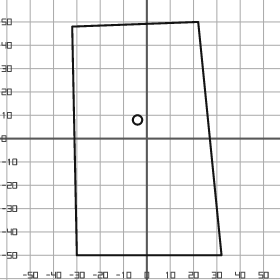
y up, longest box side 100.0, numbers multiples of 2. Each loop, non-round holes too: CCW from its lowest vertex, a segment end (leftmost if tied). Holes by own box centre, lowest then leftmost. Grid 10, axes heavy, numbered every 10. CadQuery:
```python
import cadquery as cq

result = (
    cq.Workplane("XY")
    .moveTo(-30.0, -50.0)
    .lineTo(32.0, -50.0)
    .lineTo(22.0, 50.0)
    .lineTo(-32.0, 48.0)
    .close()
    .moveTo(-4.0, 8.0)
    .circle(2.0)
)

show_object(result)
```